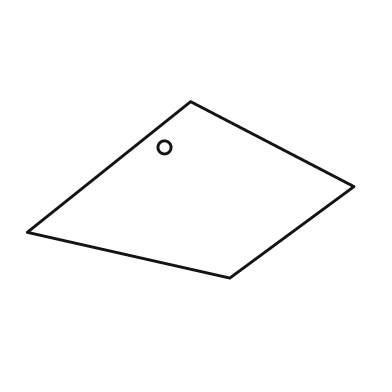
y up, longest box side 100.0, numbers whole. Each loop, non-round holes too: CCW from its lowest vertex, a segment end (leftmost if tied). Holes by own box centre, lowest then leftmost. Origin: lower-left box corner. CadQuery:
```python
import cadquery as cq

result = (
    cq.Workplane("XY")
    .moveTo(62.0, 0.0)
    .lineTo(100.0, 28.0)
    .lineTo(50.0, 54.0)
    .lineTo(0.0, 14.0)
    .close()
    .moveTo(42.0, 40.0)
    .circle(2.0)
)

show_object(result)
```